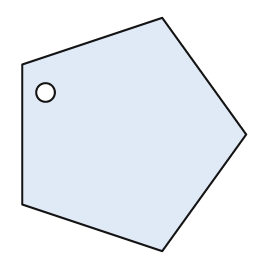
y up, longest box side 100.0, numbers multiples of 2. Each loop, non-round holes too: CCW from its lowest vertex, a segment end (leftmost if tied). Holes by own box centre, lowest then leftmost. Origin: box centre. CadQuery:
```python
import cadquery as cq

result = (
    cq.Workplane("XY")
    .moveTo(12.0, -50.0)
    .lineTo(48.0, 0.0)
    .lineTo(12.0, 50.0)
    .lineTo(-48.0, 30.0)
    .lineTo(-48.0, -30.0)
    .close()
    .moveTo(-38.0, 18.0)
    .circle(4.0)
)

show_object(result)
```